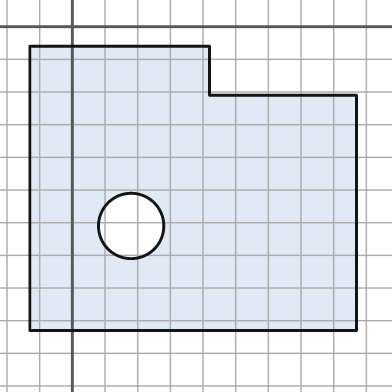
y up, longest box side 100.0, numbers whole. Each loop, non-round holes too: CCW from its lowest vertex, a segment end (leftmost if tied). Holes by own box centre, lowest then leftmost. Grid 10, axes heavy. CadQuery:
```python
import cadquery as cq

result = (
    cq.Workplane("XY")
    .moveTo(-13.0, -93.0)
    .lineTo(87.0, -93.0)
    .lineTo(87.0, -21.0)
    .lineTo(42.0, -21.0)
    .lineTo(42.0, -6.0)
    .lineTo(-13.0, -6.0)
    .close()
    .moveTo(18.0, -61.0)
    .circle(10.0)
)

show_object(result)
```